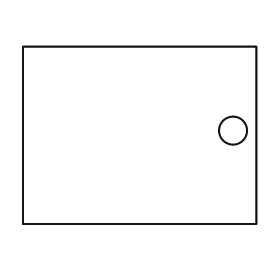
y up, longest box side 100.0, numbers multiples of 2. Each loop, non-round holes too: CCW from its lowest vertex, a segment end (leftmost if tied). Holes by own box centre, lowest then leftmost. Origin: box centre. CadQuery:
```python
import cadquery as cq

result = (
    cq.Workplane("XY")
    .moveTo(-50.0, -38.0)
    .lineTo(50.0, -38.0)
    .lineTo(50.0, 38.0)
    .lineTo(-50.0, 38.0)
    .close()
    .moveTo(40.0, 2.0)
    .circle(6.0)
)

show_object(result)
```